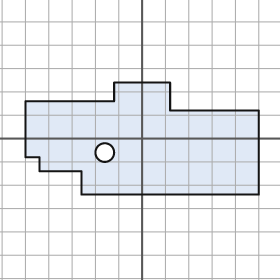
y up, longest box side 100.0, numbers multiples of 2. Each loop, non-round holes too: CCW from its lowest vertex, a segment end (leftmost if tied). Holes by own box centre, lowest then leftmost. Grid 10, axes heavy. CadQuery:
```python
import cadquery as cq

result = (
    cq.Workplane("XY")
    .moveTo(-26.0, -24.0)
    .lineTo(50.0, -24.0)
    .lineTo(50.0, 12.0)
    .lineTo(12.0, 12.0)
    .lineTo(12.0, 24.0)
    .lineTo(-12.0, 24.0)
    .lineTo(-12.0, 16.0)
    .lineTo(-50.0, 16.0)
    .lineTo(-50.0, -8.0)
    .lineTo(-44.0, -8.0)
    .lineTo(-44.0, -14.0)
    .lineTo(-26.0, -14.0)
    .close()
    .moveTo(-16.0, -6.0)
    .circle(4.0)
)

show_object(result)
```